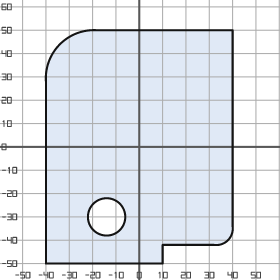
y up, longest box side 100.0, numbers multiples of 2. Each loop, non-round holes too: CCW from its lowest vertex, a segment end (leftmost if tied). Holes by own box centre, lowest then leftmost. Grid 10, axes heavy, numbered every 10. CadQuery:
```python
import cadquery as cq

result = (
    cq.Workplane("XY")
    .moveTo(-40.0, -50.0)
    .lineTo(10.0, -50.0)
    .lineTo(10.0, -42.0)
    .lineTo(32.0, -42.0)
    .threePointArc((38.0, -40.0), (40.0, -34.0))
    .lineTo(40.0, 50.0)
    .lineTo(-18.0, 50.0)
    .threePointArc((-34.0, 44.0), (-40.0, 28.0))
    .close()
    .moveTo(-14.0, -30.0)
    .circle(8.0)
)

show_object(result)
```